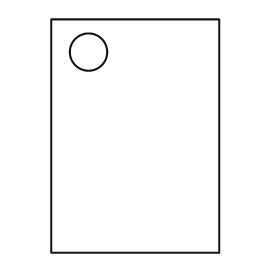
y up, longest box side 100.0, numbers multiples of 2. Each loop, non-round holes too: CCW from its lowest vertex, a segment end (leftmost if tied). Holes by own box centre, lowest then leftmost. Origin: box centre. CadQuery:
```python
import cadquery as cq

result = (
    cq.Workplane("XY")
    .moveTo(-36.0, -50.0)
    .lineTo(36.0, -50.0)
    .lineTo(36.0, 50.0)
    .lineTo(-36.0, 50.0)
    .close()
    .moveTo(-20.0, 36.0)
    .circle(8.0)
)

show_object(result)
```